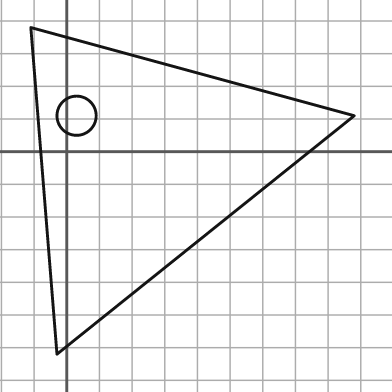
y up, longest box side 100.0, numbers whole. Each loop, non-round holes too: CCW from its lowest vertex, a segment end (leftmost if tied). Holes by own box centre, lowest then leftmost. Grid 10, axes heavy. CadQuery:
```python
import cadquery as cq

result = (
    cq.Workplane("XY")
    .moveTo(-3.0, -62.0)
    .lineTo(88.0, 11.0)
    .lineTo(-11.0, 38.0)
    .close()
    .moveTo(3.0, 11.0)
    .circle(6.0)
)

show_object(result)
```